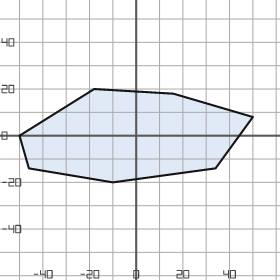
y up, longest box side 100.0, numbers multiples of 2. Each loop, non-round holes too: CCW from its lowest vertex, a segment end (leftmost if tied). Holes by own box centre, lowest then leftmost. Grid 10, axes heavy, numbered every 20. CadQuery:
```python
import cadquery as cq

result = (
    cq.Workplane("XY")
    .moveTo(-10.0, -20.0)
    .lineTo(34.0, -14.0)
    .lineTo(50.0, 8.0)
    .lineTo(16.0, 18.0)
    .lineTo(-18.0, 20.0)
    .lineTo(-50.0, 0.0)
    .lineTo(-46.0, -14.0)
    .close()
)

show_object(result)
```